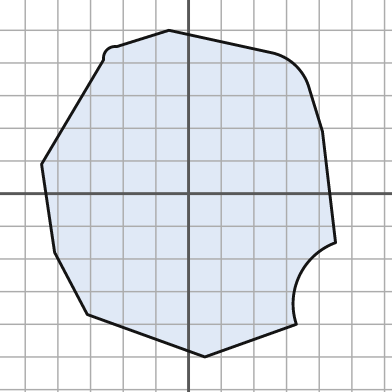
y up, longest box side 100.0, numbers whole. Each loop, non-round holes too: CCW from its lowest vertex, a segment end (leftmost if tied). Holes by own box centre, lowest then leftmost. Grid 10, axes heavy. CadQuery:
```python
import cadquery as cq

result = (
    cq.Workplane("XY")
    .moveTo(5.0, -50.0)
    .lineTo(33.0, -40.0)
    .threePointArc((34.0, -25.0), (45.0, -15.0))
    .lineTo(41.0, 19.0)
    .lineTo(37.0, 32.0)
    .threePointArc((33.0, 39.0), (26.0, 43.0))
    .lineTo(-6.0, 50.0)
    .lineTo(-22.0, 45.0)
    .threePointArc((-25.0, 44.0), (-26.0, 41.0))
    .lineTo(-45.0, 9.0)
    .lineTo(-41.0, -18.0)
    .lineTo(-31.0, -37.0)
    .close()
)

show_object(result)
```